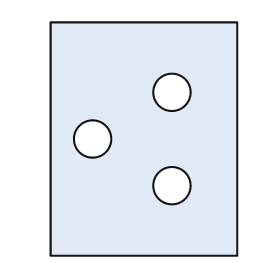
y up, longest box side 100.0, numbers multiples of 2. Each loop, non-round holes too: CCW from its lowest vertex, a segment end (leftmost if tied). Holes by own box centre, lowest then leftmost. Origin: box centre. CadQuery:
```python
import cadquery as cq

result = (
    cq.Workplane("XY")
    .moveTo(-40.0, -50.0)
    .lineTo(40.0, -50.0)
    .lineTo(40.0, 50.0)
    .lineTo(-40.0, 50.0)
    .close()
    .moveTo(12.0, -20.0)
    .circle(8.0)
    .moveTo(-22.0, 0.0)
    .circle(8.0)
    .moveTo(12.0, 20.0)
    .circle(8.0)
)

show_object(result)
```